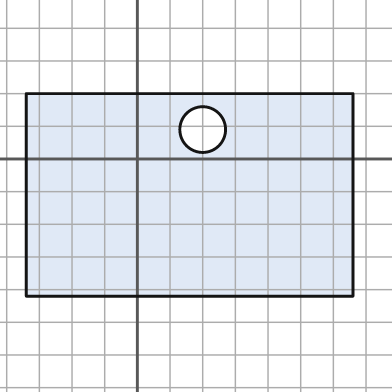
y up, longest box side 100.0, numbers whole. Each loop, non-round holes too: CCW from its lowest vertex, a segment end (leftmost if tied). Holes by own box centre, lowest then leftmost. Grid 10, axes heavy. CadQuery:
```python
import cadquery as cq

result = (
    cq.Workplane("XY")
    .moveTo(-34.0, -42.0)
    .lineTo(66.0, -42.0)
    .lineTo(66.0, 20.0)
    .lineTo(-34.0, 20.0)
    .close()
    .moveTo(20.0, 9.0)
    .circle(7.0)
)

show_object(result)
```